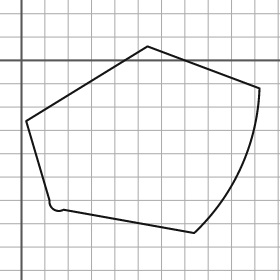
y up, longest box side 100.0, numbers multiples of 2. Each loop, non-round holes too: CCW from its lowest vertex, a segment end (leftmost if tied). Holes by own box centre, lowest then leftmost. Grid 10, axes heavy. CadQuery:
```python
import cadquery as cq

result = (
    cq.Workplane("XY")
    .moveTo(74.0, -74.0)
    .threePointArc((94.0, -46.0), (102.0, -12.0))
    .lineTo(54.0, 6.0)
    .lineTo(2.0, -26.0)
    .lineTo(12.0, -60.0)
    .threePointArc((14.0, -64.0), (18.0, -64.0))
    .close()
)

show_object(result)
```